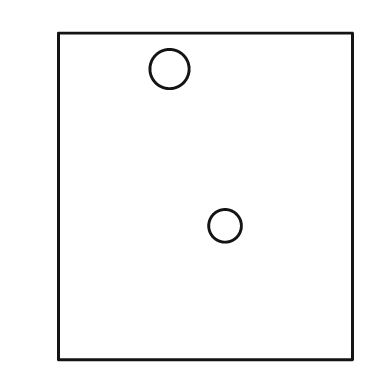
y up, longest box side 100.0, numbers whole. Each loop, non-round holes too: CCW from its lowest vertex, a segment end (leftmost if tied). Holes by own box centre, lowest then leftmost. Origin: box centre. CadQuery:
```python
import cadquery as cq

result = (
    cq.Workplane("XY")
    .moveTo(-45.0, -50.0)
    .lineTo(45.0, -50.0)
    .lineTo(45.0, 50.0)
    .lineTo(-45.0, 50.0)
    .close()
    .moveTo(6.0, -9.0)
    .circle(5.0)
    .moveTo(-11.0, 39.0)
    .circle(6.0)
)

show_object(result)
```